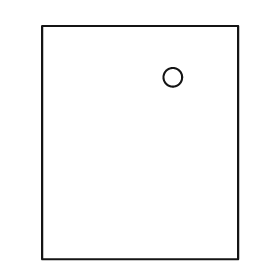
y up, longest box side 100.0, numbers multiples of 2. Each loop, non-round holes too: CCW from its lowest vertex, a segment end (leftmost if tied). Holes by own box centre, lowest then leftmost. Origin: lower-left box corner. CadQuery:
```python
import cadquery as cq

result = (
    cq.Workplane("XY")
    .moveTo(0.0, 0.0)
    .lineTo(84.0, 0.0)
    .lineTo(84.0, 100.0)
    .lineTo(0.0, 100.0)
    .close()
    .moveTo(56.0, 78.0)
    .circle(4.0)
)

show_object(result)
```